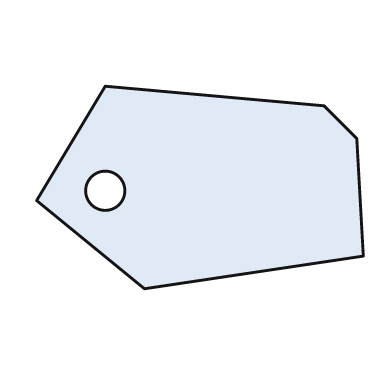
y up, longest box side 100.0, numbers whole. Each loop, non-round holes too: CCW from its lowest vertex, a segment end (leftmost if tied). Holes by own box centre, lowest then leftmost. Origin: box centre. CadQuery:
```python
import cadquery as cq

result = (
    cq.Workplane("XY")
    .moveTo(-17.0, -31.0)
    .lineTo(50.0, -21.0)
    .lineTo(48.0, 15.0)
    .lineTo(38.0, 25.0)
    .lineTo(-29.0, 31.0)
    .lineTo(-50.0, -4.0)
    .close()
    .moveTo(-29.0, -1.0)
    .circle(6.0)
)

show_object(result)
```